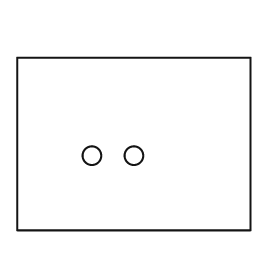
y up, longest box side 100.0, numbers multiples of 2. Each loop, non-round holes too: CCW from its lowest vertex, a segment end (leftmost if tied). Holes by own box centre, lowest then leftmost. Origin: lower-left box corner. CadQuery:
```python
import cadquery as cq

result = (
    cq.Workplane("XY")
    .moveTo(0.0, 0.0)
    .lineTo(100.0, 0.0)
    .lineTo(100.0, 74.0)
    .lineTo(0.0, 74.0)
    .close()
    .moveTo(32.0, 32.0)
    .circle(4.0)
    .moveTo(50.0, 32.0)
    .circle(4.0)
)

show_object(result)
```